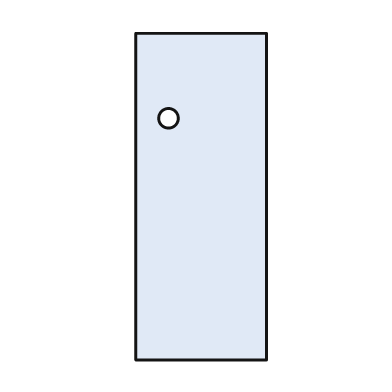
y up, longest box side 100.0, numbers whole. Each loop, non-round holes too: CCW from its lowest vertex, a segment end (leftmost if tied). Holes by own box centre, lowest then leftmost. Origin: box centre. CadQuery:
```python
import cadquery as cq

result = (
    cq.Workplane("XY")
    .moveTo(-20.0, -50.0)
    .lineTo(20.0, -50.0)
    .lineTo(20.0, 50.0)
    .lineTo(-20.0, 50.0)
    .close()
    .moveTo(-10.0, 24.0)
    .circle(3.0)
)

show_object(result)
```